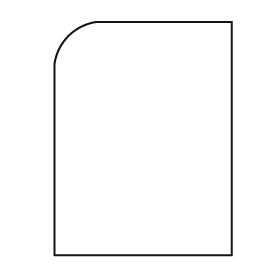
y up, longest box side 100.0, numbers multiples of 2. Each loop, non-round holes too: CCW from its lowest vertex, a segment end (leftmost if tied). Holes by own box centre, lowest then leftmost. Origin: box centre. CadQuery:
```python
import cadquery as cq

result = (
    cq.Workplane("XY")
    .moveTo(-38.0, -50.0)
    .lineTo(38.0, -50.0)
    .lineTo(38.0, 50.0)
    .lineTo(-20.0, 50.0)
    .threePointArc((-32.0, 44.0), (-38.0, 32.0))
    .close()
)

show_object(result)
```